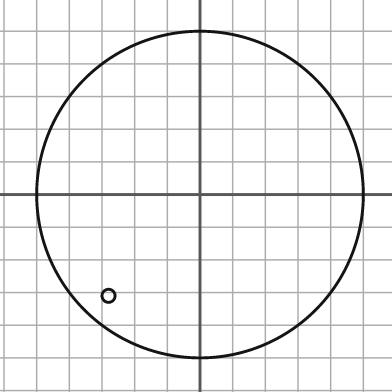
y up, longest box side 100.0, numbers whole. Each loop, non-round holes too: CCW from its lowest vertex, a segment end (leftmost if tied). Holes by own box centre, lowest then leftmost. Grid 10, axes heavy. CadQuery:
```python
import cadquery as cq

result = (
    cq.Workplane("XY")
    .moveTo(0.0, 0.0)
    .circle(50.0)
    .moveTo(-28.0, -31.0)
    .circle(2.0)
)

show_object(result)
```